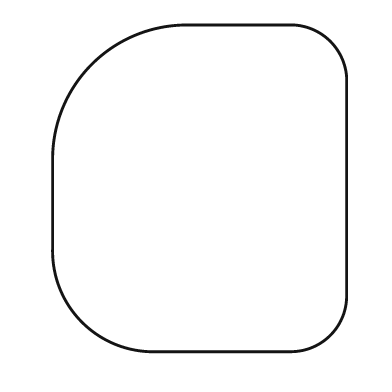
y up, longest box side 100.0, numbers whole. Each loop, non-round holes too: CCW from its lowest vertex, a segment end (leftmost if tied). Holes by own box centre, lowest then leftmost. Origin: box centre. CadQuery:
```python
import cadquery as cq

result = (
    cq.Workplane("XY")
    .moveTo(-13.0, -50.0)
    .lineTo(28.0, -50.0)
    .threePointArc((40.0, -45.0), (45.0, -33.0))
    .lineTo(45.0, 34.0)
    .threePointArc((40.0, 45.0), (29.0, 50.0))
    .lineTo(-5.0, 50.0)
    .threePointArc((-33.0, 38.0), (-45.0, 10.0))
    .lineTo(-45.0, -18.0)
    .threePointArc((-36.0, -41.0), (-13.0, -50.0))
    .close()
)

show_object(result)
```